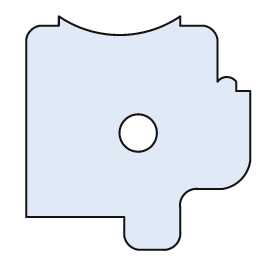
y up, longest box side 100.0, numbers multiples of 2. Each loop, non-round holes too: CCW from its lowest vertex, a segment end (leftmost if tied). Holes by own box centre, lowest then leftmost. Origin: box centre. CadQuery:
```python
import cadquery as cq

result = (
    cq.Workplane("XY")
    .moveTo(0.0, -50.0)
    .lineTo(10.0, -50.0)
    .threePointArc((16.0, -48.0), (18.0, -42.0))
    .lineTo(18.0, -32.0)
    .threePointArc((20.0, -26.0), (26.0, -24.0))
    .lineTo(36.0, -24.0)
    .threePointArc((44.0, -20.0), (48.0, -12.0))
    .lineTo(48.0, 18.0)
    .lineTo(42.0, 18.0)
    .lineTo(42.0, 22.0)
    .threePointArc((38.0, 24.0), (34.0, 22.0))
    .lineTo(34.0, 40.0)
    .threePointArc((32.0, 44.0), (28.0, 46.0))
    .lineTo(18.0, 46.0)
    .lineTo(18.0, 50.0)
    .threePointArc((-8.0, 42.0), (-34.0, 50.0))
    .lineTo(-34.0, 46.0)
    .lineTo(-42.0, 46.0)
    .threePointArc((-46.0, 44.0), (-48.0, 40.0))
    .lineTo(-48.0, -36.0)
    .lineTo(-6.0, -36.0)
    .lineTo(-6.0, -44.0)
    .threePointArc((-4.0, -48.0), (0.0, -50.0))
    .close()
    .moveTo(0.0, 0.0)
    .circle(8.0)
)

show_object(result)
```